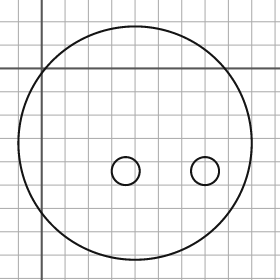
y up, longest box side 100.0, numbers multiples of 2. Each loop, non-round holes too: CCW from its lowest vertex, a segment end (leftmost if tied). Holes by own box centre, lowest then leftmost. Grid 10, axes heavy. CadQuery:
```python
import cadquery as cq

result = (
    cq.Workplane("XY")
    .moveTo(40.0, -32.0)
    .circle(50.0)
    .moveTo(36.0, -44.0)
    .circle(6.0)
    .moveTo(70.0, -44.0)
    .circle(6.0)
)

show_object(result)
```